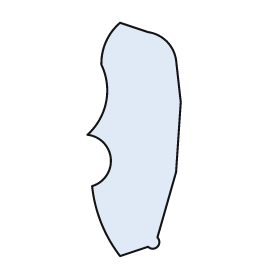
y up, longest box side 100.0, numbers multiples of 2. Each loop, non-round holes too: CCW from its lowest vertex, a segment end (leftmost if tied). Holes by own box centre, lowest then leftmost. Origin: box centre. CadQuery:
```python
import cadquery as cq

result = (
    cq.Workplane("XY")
    .moveTo(-6.0, -50.0)
    .lineTo(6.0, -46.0)
    .threePointArc((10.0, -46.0), (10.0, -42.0))
    .lineTo(18.0, -14.0)
    .lineTo(20.0, 16.0)
    .lineTo(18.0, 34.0)
    .threePointArc((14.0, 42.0), (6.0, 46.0))
    .lineTo(-6.0, 50.0)
    .threePointArc((-12.0, 42.0), (-14.0, 32.0))
    .threePointArc((-12.0, 16.0), (-20.0, 2.0))
    .threePointArc((-10.0, -8.0), (-18.0, -20.0))
    .threePointArc((-14.0, -36.0), (-6.0, -50.0))
    .close()
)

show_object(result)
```